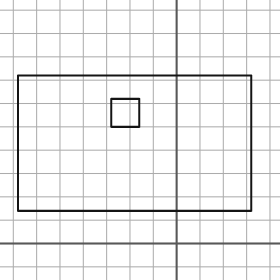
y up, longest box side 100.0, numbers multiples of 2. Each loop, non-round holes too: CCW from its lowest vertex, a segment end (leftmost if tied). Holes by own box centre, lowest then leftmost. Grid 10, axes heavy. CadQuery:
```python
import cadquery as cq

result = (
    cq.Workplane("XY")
    .moveTo(-68.0, 14.0)
    .lineTo(32.0, 14.0)
    .lineTo(32.0, 72.0)
    .lineTo(-68.0, 72.0)
    .close()
    .moveTo(-28.0, 50.0)
    .lineTo(-16.0, 50.0)
    .lineTo(-16.0, 62.0)
    .lineTo(-28.0, 62.0)
    .close()
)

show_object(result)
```